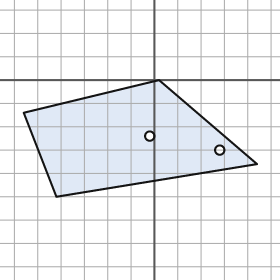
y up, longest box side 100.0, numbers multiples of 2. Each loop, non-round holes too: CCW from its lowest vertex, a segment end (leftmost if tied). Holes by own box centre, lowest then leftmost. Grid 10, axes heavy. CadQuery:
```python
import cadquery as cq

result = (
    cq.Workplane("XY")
    .moveTo(-42.0, -50.0)
    .lineTo(44.0, -36.0)
    .lineTo(2.0, 0.0)
    .lineTo(-56.0, -14.0)
    .close()
    .moveTo(28.0, -30.0)
    .circle(2.0)
    .moveTo(-2.0, -24.0)
    .circle(2.0)
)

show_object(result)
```